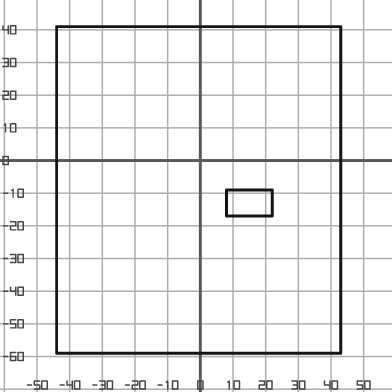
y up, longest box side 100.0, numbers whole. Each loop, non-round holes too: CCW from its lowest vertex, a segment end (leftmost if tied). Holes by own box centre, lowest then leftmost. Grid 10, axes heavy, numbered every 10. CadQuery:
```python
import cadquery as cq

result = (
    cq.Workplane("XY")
    .moveTo(-44.0, -59.0)
    .lineTo(43.0, -59.0)
    .lineTo(43.0, 41.0)
    .lineTo(-44.0, 41.0)
    .close()
    .moveTo(8.0, -17.0)
    .lineTo(22.0, -17.0)
    .lineTo(22.0, -9.0)
    .lineTo(8.0, -9.0)
    .close()
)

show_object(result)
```